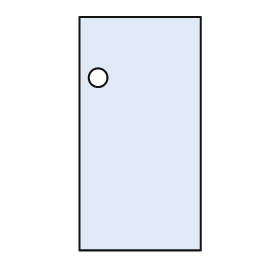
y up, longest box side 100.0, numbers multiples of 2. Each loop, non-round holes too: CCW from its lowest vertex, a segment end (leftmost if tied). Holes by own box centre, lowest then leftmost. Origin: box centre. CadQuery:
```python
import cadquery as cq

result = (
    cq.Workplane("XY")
    .moveTo(-26.0, -50.0)
    .lineTo(26.0, -50.0)
    .lineTo(26.0, 50.0)
    .lineTo(-26.0, 50.0)
    .close()
    .moveTo(-18.0, 24.0)
    .circle(4.0)
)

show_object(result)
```